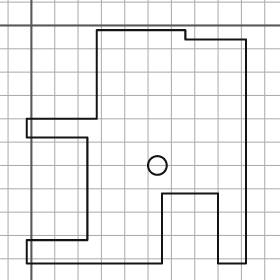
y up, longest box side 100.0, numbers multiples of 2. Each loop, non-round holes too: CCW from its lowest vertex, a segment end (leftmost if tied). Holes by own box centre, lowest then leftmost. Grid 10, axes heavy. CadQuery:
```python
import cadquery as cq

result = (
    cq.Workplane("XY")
    .moveTo(-2.0, -102.0)
    .lineTo(56.0, -102.0)
    .lineTo(56.0, -72.0)
    .lineTo(80.0, -72.0)
    .lineTo(80.0, -102.0)
    .lineTo(92.0, -102.0)
    .lineTo(92.0, -6.0)
    .lineTo(66.0, -6.0)
    .lineTo(66.0, -2.0)
    .lineTo(28.0, -2.0)
    .lineTo(28.0, -40.0)
    .lineTo(-2.0, -40.0)
    .lineTo(-2.0, -48.0)
    .lineTo(24.0, -48.0)
    .lineTo(24.0, -92.0)
    .lineTo(-2.0, -92.0)
    .close()
    .moveTo(54.0, -60.0)
    .circle(4.0)
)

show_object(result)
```